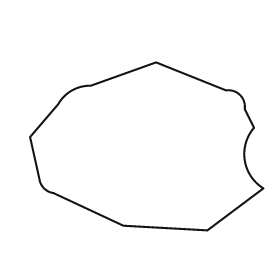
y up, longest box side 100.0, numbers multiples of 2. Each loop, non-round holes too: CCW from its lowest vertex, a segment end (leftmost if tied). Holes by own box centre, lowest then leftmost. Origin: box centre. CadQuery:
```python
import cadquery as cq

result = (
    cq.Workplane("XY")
    .moveTo(26.0, -36.0)
    .lineTo(50.0, -18.0)
    .threePointArc((42.0, -6.0), (46.0, 8.0))
    .lineTo(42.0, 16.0)
    .threePointArc((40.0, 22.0), (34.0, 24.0))
    .lineTo(4.0, 36.0)
    .lineTo(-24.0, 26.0)
    .threePointArc((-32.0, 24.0), (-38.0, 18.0))
    .lineTo(-50.0, 4.0)
    .lineTo(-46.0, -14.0)
    .threePointArc((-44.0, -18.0), (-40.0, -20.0))
    .lineTo(-10.0, -34.0)
    .close()
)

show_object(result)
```